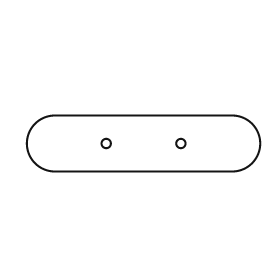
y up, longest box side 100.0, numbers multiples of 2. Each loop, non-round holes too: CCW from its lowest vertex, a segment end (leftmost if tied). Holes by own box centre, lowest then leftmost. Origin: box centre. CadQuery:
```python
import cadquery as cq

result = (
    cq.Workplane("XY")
    .moveTo(-38.0, -12.0)
    .lineTo(38.0, -12.0)
    .threePointArc((50.0, 0.0), (38.0, 12.0))
    .lineTo(-38.0, 12.0)
    .threePointArc((-50.0, 0.0), (-38.0, -12.0))
    .close()
    .moveTo(-16.0, 0.0)
    .circle(2.0)
    .moveTo(16.0, 0.0)
    .circle(2.0)
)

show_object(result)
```